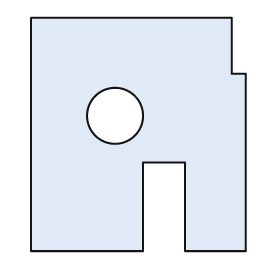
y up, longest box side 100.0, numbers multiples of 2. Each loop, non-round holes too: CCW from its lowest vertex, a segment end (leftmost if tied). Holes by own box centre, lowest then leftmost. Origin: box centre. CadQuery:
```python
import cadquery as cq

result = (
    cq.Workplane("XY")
    .moveTo(-46.0, -50.0)
    .lineTo(2.0, -50.0)
    .lineTo(2.0, -12.0)
    .lineTo(20.0, -12.0)
    .lineTo(20.0, -50.0)
    .lineTo(46.0, -50.0)
    .lineTo(46.0, 26.0)
    .lineTo(40.0, 26.0)
    .lineTo(40.0, 50.0)
    .lineTo(-46.0, 50.0)
    .close()
    .moveTo(-10.0, 8.0)
    .circle(12.0)
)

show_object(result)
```